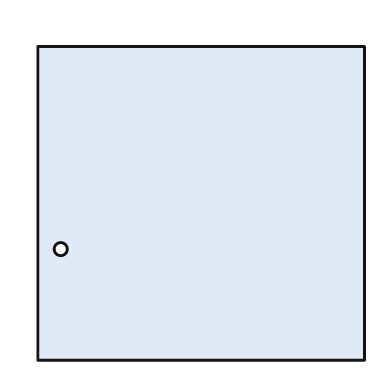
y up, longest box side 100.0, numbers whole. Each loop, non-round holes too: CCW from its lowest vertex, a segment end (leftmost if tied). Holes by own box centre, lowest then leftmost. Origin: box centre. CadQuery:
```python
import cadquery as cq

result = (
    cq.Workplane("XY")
    .moveTo(-50.0, -48.0)
    .lineTo(50.0, -48.0)
    .lineTo(50.0, 48.0)
    .lineTo(-50.0, 48.0)
    .close()
    .moveTo(-43.0, -14.0)
    .circle(2.0)
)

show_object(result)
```